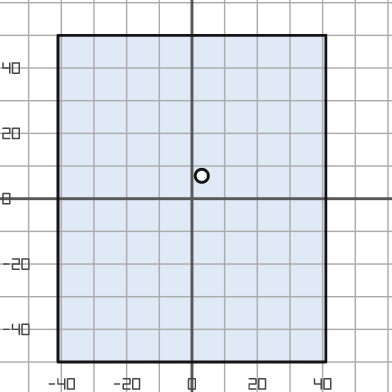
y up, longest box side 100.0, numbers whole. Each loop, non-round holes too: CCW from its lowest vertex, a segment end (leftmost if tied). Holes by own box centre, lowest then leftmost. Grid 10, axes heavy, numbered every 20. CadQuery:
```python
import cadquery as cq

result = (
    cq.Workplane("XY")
    .moveTo(-41.0, -50.0)
    .lineTo(41.0, -50.0)
    .lineTo(41.0, 50.0)
    .lineTo(-41.0, 50.0)
    .close()
    .moveTo(3.0, 7.0)
    .circle(2.0)
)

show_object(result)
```